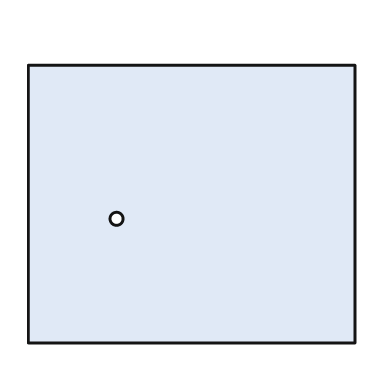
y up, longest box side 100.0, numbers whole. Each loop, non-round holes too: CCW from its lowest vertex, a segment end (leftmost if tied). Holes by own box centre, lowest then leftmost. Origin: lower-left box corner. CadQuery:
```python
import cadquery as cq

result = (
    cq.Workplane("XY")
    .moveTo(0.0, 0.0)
    .lineTo(100.0, 0.0)
    .lineTo(100.0, 85.0)
    .lineTo(0.0, 85.0)
    .close()
    .moveTo(27.0, 38.0)
    .circle(2.0)
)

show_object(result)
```